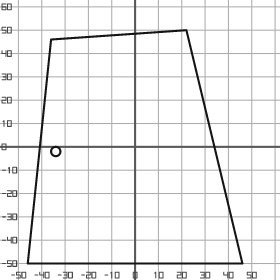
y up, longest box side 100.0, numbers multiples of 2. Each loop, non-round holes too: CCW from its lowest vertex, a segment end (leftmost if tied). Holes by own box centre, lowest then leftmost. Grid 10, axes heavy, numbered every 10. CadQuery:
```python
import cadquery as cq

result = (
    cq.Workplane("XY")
    .moveTo(-46.0, -50.0)
    .lineTo(46.0, -50.0)
    .lineTo(22.0, 50.0)
    .lineTo(-36.0, 46.0)
    .close()
    .moveTo(-34.0, -2.0)
    .circle(2.0)
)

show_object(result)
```